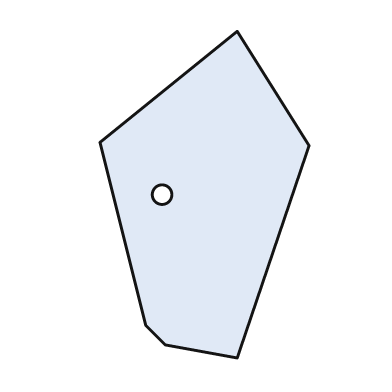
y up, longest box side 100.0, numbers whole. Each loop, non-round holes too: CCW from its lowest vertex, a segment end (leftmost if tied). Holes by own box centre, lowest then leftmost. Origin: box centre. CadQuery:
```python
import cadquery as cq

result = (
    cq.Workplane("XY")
    .moveTo(10.0, -50.0)
    .lineTo(32.0, 15.0)
    .lineTo(10.0, 50.0)
    .lineTo(-32.0, 16.0)
    .lineTo(-18.0, -40.0)
    .lineTo(-12.0, -46.0)
    .close()
    .moveTo(-13.0, 0.0)
    .circle(3.0)
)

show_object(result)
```